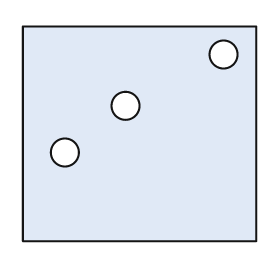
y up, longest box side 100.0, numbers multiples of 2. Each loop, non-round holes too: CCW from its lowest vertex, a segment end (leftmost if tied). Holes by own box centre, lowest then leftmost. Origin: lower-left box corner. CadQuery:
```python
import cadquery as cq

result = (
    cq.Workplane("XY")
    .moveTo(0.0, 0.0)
    .lineTo(100.0, 0.0)
    .lineTo(100.0, 92.0)
    .lineTo(0.0, 92.0)
    .close()
    .moveTo(18.0, 38.0)
    .circle(6.0)
    .moveTo(44.0, 58.0)
    .circle(6.0)
    .moveTo(86.0, 80.0)
    .circle(6.0)
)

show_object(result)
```